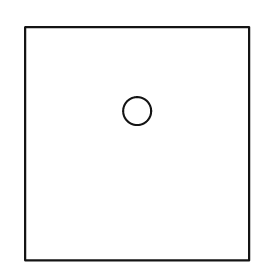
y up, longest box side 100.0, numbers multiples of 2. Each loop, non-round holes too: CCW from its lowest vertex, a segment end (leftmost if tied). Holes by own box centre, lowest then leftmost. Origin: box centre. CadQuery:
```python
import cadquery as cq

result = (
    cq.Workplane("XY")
    .moveTo(-48.0, -50.0)
    .lineTo(48.0, -50.0)
    .lineTo(48.0, 50.0)
    .lineTo(-48.0, 50.0)
    .close()
    .moveTo(0.0, 14.0)
    .circle(6.0)
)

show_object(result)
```